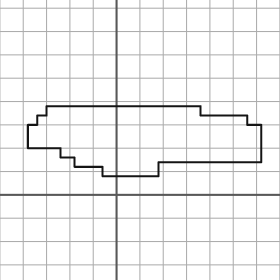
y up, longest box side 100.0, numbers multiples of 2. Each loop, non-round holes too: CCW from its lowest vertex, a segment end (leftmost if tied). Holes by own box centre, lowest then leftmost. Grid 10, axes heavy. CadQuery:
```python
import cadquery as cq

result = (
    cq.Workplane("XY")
    .moveTo(-6.0, 8.0)
    .lineTo(18.0, 8.0)
    .lineTo(18.0, 14.0)
    .lineTo(62.0, 14.0)
    .lineTo(62.0, 30.0)
    .lineTo(56.0, 30.0)
    .lineTo(56.0, 34.0)
    .lineTo(36.0, 34.0)
    .lineTo(36.0, 38.0)
    .lineTo(-30.0, 38.0)
    .lineTo(-30.0, 34.0)
    .lineTo(-34.0, 34.0)
    .lineTo(-34.0, 30.0)
    .lineTo(-38.0, 30.0)
    .lineTo(-38.0, 20.0)
    .lineTo(-24.0, 20.0)
    .lineTo(-24.0, 16.0)
    .lineTo(-18.0, 16.0)
    .lineTo(-18.0, 12.0)
    .lineTo(-6.0, 12.0)
    .close()
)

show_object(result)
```